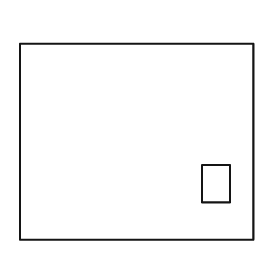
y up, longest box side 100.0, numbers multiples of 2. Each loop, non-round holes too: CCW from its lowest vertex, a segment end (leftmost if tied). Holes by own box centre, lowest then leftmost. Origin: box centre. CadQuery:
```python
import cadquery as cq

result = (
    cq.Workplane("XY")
    .moveTo(-50.0, -42.0)
    .lineTo(50.0, -42.0)
    .lineTo(50.0, 42.0)
    .lineTo(-50.0, 42.0)
    .close()
    .moveTo(28.0, -26.0)
    .lineTo(40.0, -26.0)
    .lineTo(40.0, -10.0)
    .lineTo(28.0, -10.0)
    .close()
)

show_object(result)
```